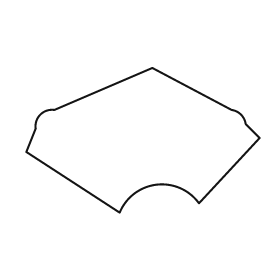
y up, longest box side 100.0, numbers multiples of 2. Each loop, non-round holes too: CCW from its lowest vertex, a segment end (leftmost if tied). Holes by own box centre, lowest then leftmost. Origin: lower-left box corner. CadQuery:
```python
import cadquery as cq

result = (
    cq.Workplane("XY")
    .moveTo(40.0, 0.0)
    .threePointArc((56.0, 12.0), (74.0, 4.0))
    .lineTo(100.0, 32.0)
    .lineTo(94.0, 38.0)
    .threePointArc((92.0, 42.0), (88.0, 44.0))
    .lineTo(54.0, 62.0)
    .lineTo(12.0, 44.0)
    .threePointArc((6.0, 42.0), (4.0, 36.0))
    .lineTo(0.0, 26.0)
    .close()
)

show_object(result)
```